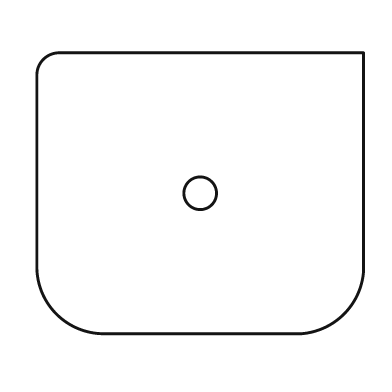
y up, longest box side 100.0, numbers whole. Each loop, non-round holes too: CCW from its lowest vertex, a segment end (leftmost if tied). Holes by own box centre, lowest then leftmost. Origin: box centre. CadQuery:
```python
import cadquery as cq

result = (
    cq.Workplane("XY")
    .moveTo(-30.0, -43.0)
    .lineTo(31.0, -43.0)
    .threePointArc((44.0, -37.0), (50.0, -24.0))
    .lineTo(50.0, 43.0)
    .lineTo(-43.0, 43.0)
    .threePointArc((-48.0, 41.0), (-50.0, 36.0))
    .lineTo(-50.0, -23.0)
    .threePointArc((-44.0, -37.0), (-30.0, -43.0))
    .close()
    .moveTo(0.0, 0.0)
    .circle(5.0)
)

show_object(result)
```